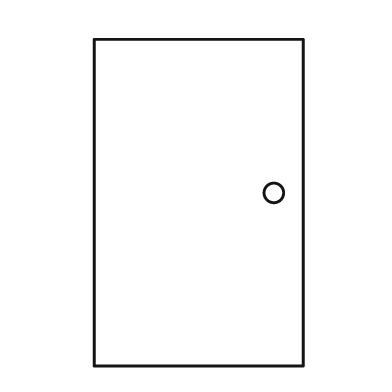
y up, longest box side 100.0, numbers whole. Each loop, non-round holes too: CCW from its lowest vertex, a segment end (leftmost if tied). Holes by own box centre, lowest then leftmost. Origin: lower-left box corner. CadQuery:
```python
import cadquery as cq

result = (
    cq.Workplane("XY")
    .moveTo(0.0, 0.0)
    .lineTo(64.0, 0.0)
    .lineTo(64.0, 100.0)
    .lineTo(0.0, 100.0)
    .close()
    .moveTo(55.0, 53.0)
    .circle(3.0)
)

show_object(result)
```